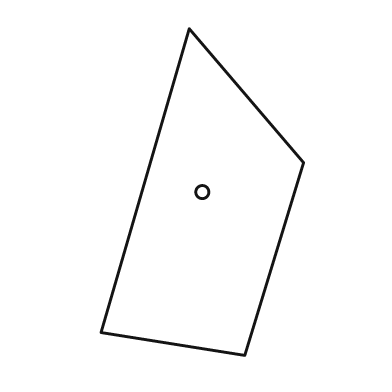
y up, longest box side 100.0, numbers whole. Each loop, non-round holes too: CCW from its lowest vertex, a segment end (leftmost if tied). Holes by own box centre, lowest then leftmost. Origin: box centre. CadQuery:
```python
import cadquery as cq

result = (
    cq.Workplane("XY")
    .moveTo(13.0, -50.0)
    .lineTo(31.0, 9.0)
    .lineTo(-4.0, 50.0)
    .lineTo(-31.0, -43.0)
    .close()
    .moveTo(0.0, 0.0)
    .circle(2.0)
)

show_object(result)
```